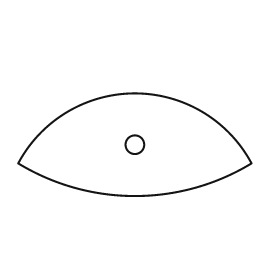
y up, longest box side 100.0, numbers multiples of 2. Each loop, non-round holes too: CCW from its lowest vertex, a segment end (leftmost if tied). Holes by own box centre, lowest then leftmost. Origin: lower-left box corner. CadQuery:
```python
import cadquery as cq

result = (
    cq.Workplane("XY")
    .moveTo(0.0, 14.0)
    .threePointArc((50.0, 0.0), (100.0, 14.0))
    .threePointArc((50.0, 44.0), (0.0, 14.0))
    .close()
    .moveTo(50.0, 22.0)
    .circle(4.0)
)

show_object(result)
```